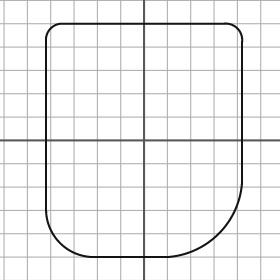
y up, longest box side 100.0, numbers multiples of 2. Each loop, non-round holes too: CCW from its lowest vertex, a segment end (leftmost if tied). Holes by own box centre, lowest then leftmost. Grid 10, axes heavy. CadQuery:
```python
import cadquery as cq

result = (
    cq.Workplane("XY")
    .moveTo(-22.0, -50.0)
    .lineTo(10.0, -50.0)
    .threePointArc((32.0, -40.0), (42.0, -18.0))
    .lineTo(42.0, 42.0)
    .threePointArc((40.0, 48.0), (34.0, 50.0))
    .lineTo(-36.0, 50.0)
    .threePointArc((-40.0, 48.0), (-42.0, 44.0))
    .lineTo(-42.0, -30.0)
    .threePointArc((-36.0, -44.0), (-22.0, -50.0))
    .close()
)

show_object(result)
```